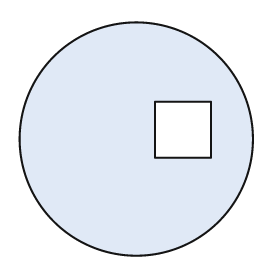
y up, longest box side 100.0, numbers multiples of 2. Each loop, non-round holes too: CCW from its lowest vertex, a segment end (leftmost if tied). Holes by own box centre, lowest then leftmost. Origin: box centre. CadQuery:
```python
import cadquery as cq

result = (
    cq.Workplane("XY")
    .moveTo(0.0, 0.0)
    .circle(50.0)
    .moveTo(8.0, -8.0)
    .lineTo(32.0, -8.0)
    .lineTo(32.0, 16.0)
    .lineTo(8.0, 16.0)
    .close()
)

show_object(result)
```